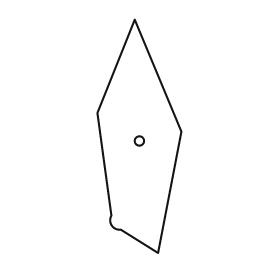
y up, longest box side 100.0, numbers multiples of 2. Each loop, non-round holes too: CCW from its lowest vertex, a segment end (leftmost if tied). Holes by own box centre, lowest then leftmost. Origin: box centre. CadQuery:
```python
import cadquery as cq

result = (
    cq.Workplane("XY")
    .moveTo(8.0, -50.0)
    .lineTo(18.0, 2.0)
    .lineTo(-2.0, 50.0)
    .lineTo(-18.0, 10.0)
    .lineTo(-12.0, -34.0)
    .threePointArc((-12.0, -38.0), (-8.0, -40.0))
    .close()
    .moveTo(0.0, -2.0)
    .circle(2.0)
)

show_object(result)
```